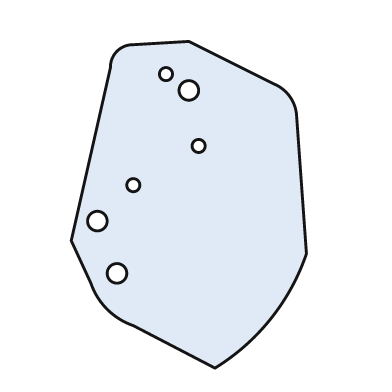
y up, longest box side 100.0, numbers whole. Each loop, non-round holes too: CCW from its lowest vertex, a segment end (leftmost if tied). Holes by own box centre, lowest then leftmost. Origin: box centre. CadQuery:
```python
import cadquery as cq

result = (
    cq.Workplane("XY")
    .moveTo(8.0, -50.0)
    .threePointArc((25.0, -35.0), (36.0, -15.0))
    .lineTo(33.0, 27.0)
    .threePointArc((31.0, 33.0), (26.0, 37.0))
    .lineTo(0.0, 50.0)
    .lineTo(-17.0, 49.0)
    .threePointArc((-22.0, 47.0), (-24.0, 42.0))
    .lineTo(-36.0, -11.0)
    .lineTo(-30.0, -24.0)
    .threePointArc((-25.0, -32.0), (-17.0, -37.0))
    .close()
    .moveTo(-22.0, -21.0)
    .circle(3.0)
    .moveTo(-28.0, -5.0)
    .circle(3.0)
    .moveTo(-17.0, 6.0)
    .circle(2.0)
    .moveTo(3.0, 18.0)
    .circle(2.0)
    .moveTo(0.0, 35.0)
    .circle(3.0)
    .moveTo(-7.0, 40.0)
    .circle(2.0)
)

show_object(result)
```